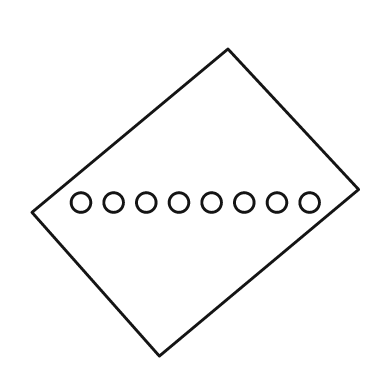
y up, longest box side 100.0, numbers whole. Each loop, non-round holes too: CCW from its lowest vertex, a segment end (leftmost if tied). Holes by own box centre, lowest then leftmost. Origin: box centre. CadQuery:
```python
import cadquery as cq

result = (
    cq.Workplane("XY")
    .moveTo(-11.0, -47.0)
    .lineTo(50.0, 4.0)
    .lineTo(10.0, 47.0)
    .lineTo(-50.0, -3.0)
    .close()
    .moveTo(-35.0, 0.0)
    .circle(3.0)
    .moveTo(-25.0, 0.0)
    .circle(3.0)
    .moveTo(-15.0, 0.0)
    .circle(3.0)
    .moveTo(-5.0, 0.0)
    .circle(3.0)
    .moveTo(5.0, 0.0)
    .circle(3.0)
    .moveTo(15.0, 0.0)
    .circle(3.0)
    .moveTo(25.0, 0.0)
    .circle(3.0)
    .moveTo(35.0, 0.0)
    .circle(3.0)
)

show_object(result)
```